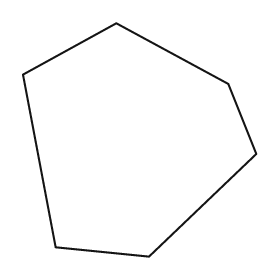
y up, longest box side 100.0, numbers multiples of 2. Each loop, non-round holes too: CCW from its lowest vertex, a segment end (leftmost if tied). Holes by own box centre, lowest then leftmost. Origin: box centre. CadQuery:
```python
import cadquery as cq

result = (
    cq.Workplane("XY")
    .moveTo(4.0, -50.0)
    .lineTo(50.0, -6.0)
    .lineTo(38.0, 24.0)
    .lineTo(-10.0, 50.0)
    .lineTo(-50.0, 28.0)
    .lineTo(-36.0, -46.0)
    .close()
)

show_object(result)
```